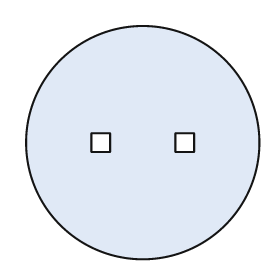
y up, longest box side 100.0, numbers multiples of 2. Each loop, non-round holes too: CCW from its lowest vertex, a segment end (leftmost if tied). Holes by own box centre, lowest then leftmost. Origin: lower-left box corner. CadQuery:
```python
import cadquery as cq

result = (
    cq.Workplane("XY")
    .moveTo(50.0, 50.0)
    .circle(50.0)
    .moveTo(28.0, 46.0)
    .lineTo(36.0, 46.0)
    .lineTo(36.0, 54.0)
    .lineTo(28.0, 54.0)
    .close()
    .moveTo(64.0, 46.0)
    .lineTo(72.0, 46.0)
    .lineTo(72.0, 54.0)
    .lineTo(64.0, 54.0)
    .close()
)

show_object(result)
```